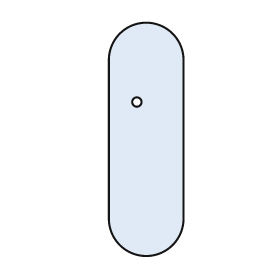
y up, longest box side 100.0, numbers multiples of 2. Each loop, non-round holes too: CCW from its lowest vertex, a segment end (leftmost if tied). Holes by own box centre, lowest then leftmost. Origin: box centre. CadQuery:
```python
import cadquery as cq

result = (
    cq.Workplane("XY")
    .moveTo(-16.0, -34.0)
    .threePointArc((0.0, -50.0), (16.0, -34.0))
    .lineTo(16.0, 34.0)
    .threePointArc((0.0, 50.0), (-16.0, 34.0))
    .close()
    .moveTo(-4.0, 16.0)
    .circle(2.0)
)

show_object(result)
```